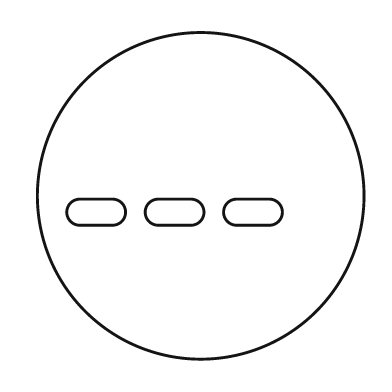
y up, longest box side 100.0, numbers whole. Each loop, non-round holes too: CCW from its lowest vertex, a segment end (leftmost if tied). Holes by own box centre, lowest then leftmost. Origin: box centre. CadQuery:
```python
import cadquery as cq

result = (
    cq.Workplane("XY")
    .moveTo(0.0, 0.0)
    .circle(50.0)
    .moveTo(-37.0, -9.0)
    .lineTo(-27.0, -9.0)
    .threePointArc((-23.0, -5.0), (-27.0, -1.0))
    .lineTo(-37.0, -1.0)
    .threePointArc((-41.0, -5.0), (-37.0, -9.0))
    .close()
    .moveTo(-13.0, -9.0)
    .lineTo(-3.0, -9.0)
    .threePointArc((1.0, -5.0), (-3.0, -1.0))
    .lineTo(-13.0, -1.0)
    .threePointArc((-17.0, -5.0), (-13.0, -9.0))
    .close()
    .moveTo(11.0, -9.0)
    .lineTo(21.0, -9.0)
    .threePointArc((25.0, -5.0), (21.0, -1.0))
    .lineTo(11.0, -1.0)
    .threePointArc((7.0, -5.0), (11.0, -9.0))
    .close()
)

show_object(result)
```